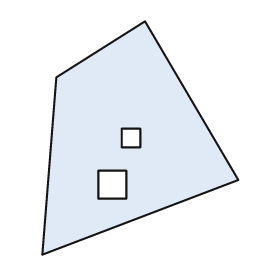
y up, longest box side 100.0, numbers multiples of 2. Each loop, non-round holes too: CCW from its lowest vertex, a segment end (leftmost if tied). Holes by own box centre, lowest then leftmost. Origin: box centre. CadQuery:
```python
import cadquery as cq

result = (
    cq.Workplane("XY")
    .moveTo(-42.0, -50.0)
    .lineTo(42.0, -18.0)
    .lineTo(2.0, 50.0)
    .lineTo(-36.0, 26.0)
    .close()
    .moveTo(-18.0, -26.0)
    .lineTo(-6.0, -26.0)
    .lineTo(-6.0, -14.0)
    .lineTo(-18.0, -14.0)
    .close()
    .moveTo(-8.0, -4.0)
    .lineTo(0.0, -4.0)
    .lineTo(0.0, 4.0)
    .lineTo(-8.0, 4.0)
    .close()
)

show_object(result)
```